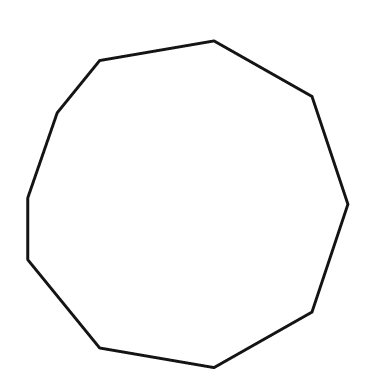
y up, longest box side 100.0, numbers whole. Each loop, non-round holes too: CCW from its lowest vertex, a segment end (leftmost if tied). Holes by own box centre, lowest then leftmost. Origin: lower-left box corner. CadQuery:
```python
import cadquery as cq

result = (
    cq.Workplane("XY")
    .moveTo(57.0, 0.0)
    .lineTo(87.0, 17.0)
    .lineTo(98.0, 50.0)
    .lineTo(87.0, 83.0)
    .lineTo(57.0, 100.0)
    .lineTo(22.0, 94.0)
    .lineTo(9.0, 78.0)
    .lineTo(0.0, 52.0)
    .lineTo(0.0, 33.0)
    .lineTo(22.0, 6.0)
    .close()
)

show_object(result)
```